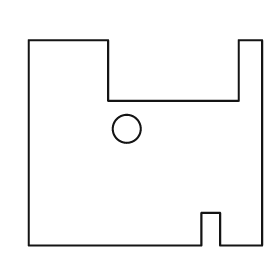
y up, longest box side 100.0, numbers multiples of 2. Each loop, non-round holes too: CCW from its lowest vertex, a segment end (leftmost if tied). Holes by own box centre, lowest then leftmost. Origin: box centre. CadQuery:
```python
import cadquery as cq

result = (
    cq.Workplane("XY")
    .moveTo(-50.0, -44.0)
    .lineTo(24.0, -44.0)
    .lineTo(24.0, -30.0)
    .lineTo(32.0, -30.0)
    .lineTo(32.0, -44.0)
    .lineTo(50.0, -44.0)
    .lineTo(50.0, 44.0)
    .lineTo(40.0, 44.0)
    .lineTo(40.0, 18.0)
    .lineTo(-16.0, 18.0)
    .lineTo(-16.0, 44.0)
    .lineTo(-50.0, 44.0)
    .close()
    .moveTo(-8.0, 6.0)
    .circle(6.0)
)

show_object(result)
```